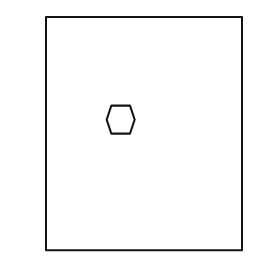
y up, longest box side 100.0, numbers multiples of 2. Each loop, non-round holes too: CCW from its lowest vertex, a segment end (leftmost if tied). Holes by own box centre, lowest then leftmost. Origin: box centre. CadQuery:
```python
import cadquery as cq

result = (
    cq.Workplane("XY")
    .moveTo(-42.0, -50.0)
    .lineTo(42.0, -50.0)
    .lineTo(42.0, 50.0)
    .lineTo(-42.0, 50.0)
    .close()
    .moveTo(-14.0, 0.0)
    .lineTo(-6.0, 0.0)
    .lineTo(-4.0, 6.0)
    .lineTo(-6.0, 12.0)
    .lineTo(-14.0, 12.0)
    .lineTo(-16.0, 6.0)
    .close()
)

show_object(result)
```